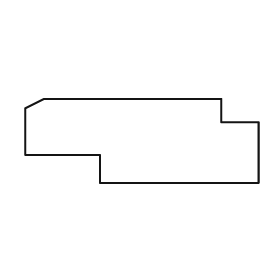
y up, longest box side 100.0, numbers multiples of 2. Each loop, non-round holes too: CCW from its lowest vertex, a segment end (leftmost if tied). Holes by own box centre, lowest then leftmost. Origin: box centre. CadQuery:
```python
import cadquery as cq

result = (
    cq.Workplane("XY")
    .moveTo(-18.0, -18.0)
    .lineTo(50.0, -18.0)
    .lineTo(50.0, 8.0)
    .lineTo(34.0, 8.0)
    .lineTo(34.0, 18.0)
    .lineTo(-42.0, 18.0)
    .lineTo(-50.0, 14.0)
    .lineTo(-50.0, -6.0)
    .lineTo(-18.0, -6.0)
    .close()
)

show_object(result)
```